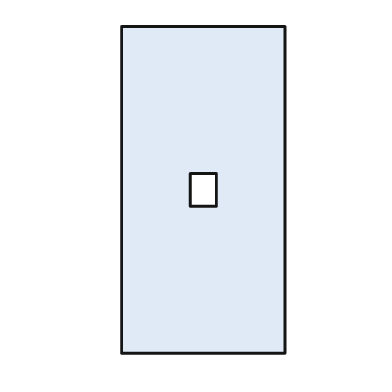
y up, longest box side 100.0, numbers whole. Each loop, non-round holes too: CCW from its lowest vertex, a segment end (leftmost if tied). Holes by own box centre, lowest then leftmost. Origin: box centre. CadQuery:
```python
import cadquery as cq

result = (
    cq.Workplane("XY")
    .moveTo(-25.0, -50.0)
    .lineTo(25.0, -50.0)
    .lineTo(25.0, 50.0)
    .lineTo(-25.0, 50.0)
    .close()
    .moveTo(-4.0, -5.0)
    .lineTo(4.0, -5.0)
    .lineTo(4.0, 5.0)
    .lineTo(-4.0, 5.0)
    .close()
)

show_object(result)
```